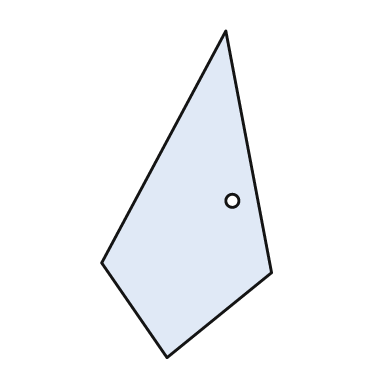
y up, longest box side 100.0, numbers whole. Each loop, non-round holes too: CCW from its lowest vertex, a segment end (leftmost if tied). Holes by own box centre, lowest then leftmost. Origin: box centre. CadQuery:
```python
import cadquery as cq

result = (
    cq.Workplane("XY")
    .moveTo(-6.0, -50.0)
    .lineTo(26.0, -24.0)
    .lineTo(12.0, 50.0)
    .lineTo(-26.0, -21.0)
    .close()
    .moveTo(14.0, -2.0)
    .circle(2.0)
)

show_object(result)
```